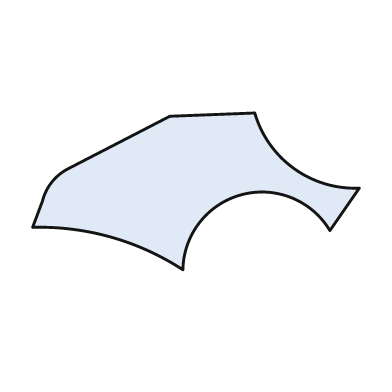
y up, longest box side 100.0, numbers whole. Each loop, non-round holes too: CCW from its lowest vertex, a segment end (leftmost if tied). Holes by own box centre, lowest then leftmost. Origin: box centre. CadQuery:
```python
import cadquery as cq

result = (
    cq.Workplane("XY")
    .moveTo(-4.0, -24.0)
    .threePointArc((14.0, -1.0), (41.0, -12.0))
    .lineTo(50.0, 1.0)
    .threePointArc((30.0, 7.0), (18.0, 24.0))
    .lineTo(-8.0, 23.0)
    .lineTo(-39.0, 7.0)
    .threePointArc((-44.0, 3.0), (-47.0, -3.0))
    .lineTo(-50.0, -11.0)
    .threePointArc((-26.0, -14.0), (-4.0, -24.0))
    .close()
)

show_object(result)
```